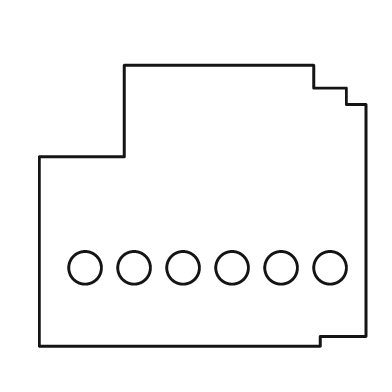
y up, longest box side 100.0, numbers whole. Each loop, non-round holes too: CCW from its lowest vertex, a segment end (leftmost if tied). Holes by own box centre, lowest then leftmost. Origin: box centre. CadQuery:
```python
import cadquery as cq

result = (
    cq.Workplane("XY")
    .moveTo(-50.0, -43.0)
    .lineTo(36.0, -43.0)
    .lineTo(36.0, -40.0)
    .lineTo(50.0, -40.0)
    .lineTo(50.0, 31.0)
    .lineTo(44.0, 31.0)
    .lineTo(44.0, 36.0)
    .lineTo(34.0, 36.0)
    .lineTo(34.0, 43.0)
    .lineTo(-24.0, 43.0)
    .lineTo(-24.0, 15.0)
    .lineTo(-50.0, 15.0)
    .close()
    .moveTo(-36.0, -19.0)
    .circle(5.0)
    .moveTo(-21.0, -19.0)
    .circle(5.0)
    .moveTo(-6.0, -19.0)
    .circle(5.0)
    .moveTo(9.0, -19.0)
    .circle(5.0)
    .moveTo(24.0, -19.0)
    .circle(5.0)
    .moveTo(39.0, -19.0)
    .circle(5.0)
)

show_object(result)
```